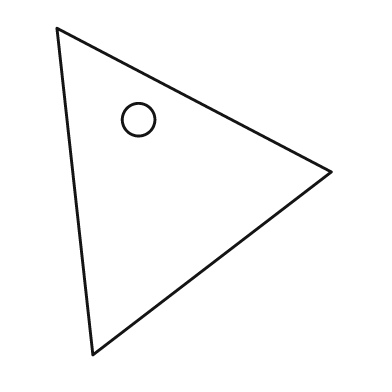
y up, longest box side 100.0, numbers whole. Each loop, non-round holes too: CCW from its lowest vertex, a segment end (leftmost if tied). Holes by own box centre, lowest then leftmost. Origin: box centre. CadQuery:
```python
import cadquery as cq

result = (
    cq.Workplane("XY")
    .moveTo(-31.0, -50.0)
    .lineTo(42.0, 6.0)
    .lineTo(-42.0, 50.0)
    .close()
    .moveTo(-17.0, 22.0)
    .circle(5.0)
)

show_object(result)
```